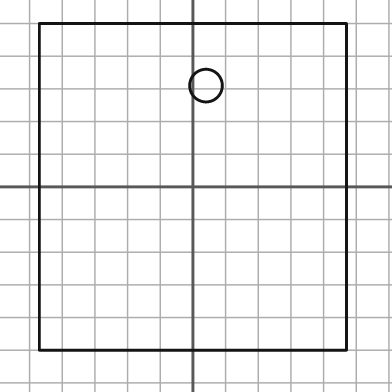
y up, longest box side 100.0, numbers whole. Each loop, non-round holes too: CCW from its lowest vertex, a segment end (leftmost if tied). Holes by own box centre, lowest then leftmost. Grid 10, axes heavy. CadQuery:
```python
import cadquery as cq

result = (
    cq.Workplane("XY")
    .moveTo(-47.0, -50.0)
    .lineTo(47.0, -50.0)
    .lineTo(47.0, 50.0)
    .lineTo(-47.0, 50.0)
    .close()
    .moveTo(4.0, 31.0)
    .circle(5.0)
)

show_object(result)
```